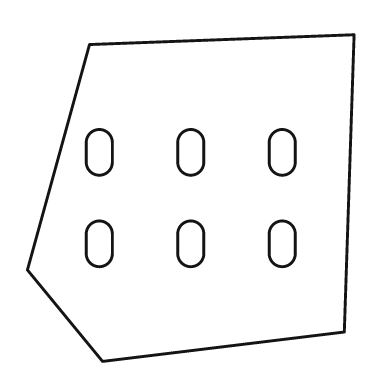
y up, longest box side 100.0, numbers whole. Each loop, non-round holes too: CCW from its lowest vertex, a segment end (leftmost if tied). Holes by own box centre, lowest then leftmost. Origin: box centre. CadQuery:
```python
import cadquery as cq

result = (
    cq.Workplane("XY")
    .moveTo(-27.0, -50.0)
    .lineTo(47.0, -41.0)
    .lineTo(50.0, 50.0)
    .lineTo(-31.0, 47.0)
    .lineTo(-50.0, -22.0)
    .close()
    .moveTo(-32.0, -17.0)
    .threePointArc((-28.0, -21.0), (-24.0, -17.0))
    .lineTo(-24.0, -11.0)
    .threePointArc((-28.0, -7.0), (-32.0, -11.0))
    .close()
    .moveTo(-4.0, -17.0)
    .threePointArc((0.0, -21.0), (4.0, -17.0))
    .lineTo(4.0, -11.0)
    .threePointArc((0.0, -7.0), (-4.0, -11.0))
    .close()
    .moveTo(24.0, -17.0)
    .threePointArc((28.0, -21.0), (32.0, -17.0))
    .lineTo(32.0, -11.0)
    .threePointArc((28.0, -7.0), (24.0, -11.0))
    .close()
    .moveTo(-32.0, 11.0)
    .threePointArc((-28.0, 7.0), (-24.0, 11.0))
    .lineTo(-24.0, 17.0)
    .threePointArc((-28.0, 21.0), (-32.0, 17.0))
    .close()
    .moveTo(-4.0, 11.0)
    .threePointArc((0.0, 7.0), (4.0, 11.0))
    .lineTo(4.0, 17.0)
    .threePointArc((0.0, 21.0), (-4.0, 17.0))
    .close()
    .moveTo(24.0, 11.0)
    .threePointArc((28.0, 7.0), (32.0, 11.0))
    .lineTo(32.0, 17.0)
    .threePointArc((28.0, 21.0), (24.0, 17.0))
    .close()
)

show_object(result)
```